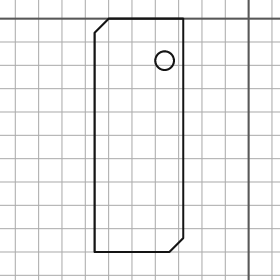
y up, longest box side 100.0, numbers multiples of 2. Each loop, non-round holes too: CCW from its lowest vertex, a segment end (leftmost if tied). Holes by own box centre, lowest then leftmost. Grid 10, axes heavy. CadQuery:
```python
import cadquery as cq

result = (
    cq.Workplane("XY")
    .moveTo(-66.0, -100.0)
    .lineTo(-34.0, -100.0)
    .lineTo(-28.0, -94.0)
    .lineTo(-28.0, 0.0)
    .lineTo(-60.0, 0.0)
    .lineTo(-66.0, -6.0)
    .close()
    .moveTo(-36.0, -18.0)
    .circle(4.0)
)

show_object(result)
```